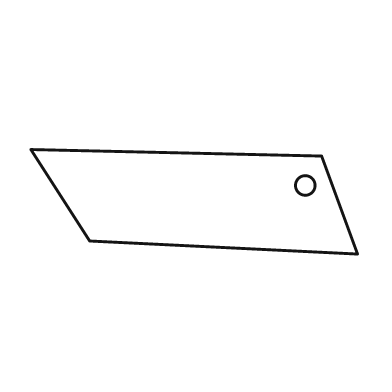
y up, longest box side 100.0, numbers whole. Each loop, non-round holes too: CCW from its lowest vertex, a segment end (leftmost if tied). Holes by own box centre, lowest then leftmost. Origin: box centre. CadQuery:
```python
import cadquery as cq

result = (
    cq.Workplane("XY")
    .moveTo(50.0, -16.0)
    .lineTo(39.0, 14.0)
    .lineTo(-50.0, 16.0)
    .lineTo(-32.0, -12.0)
    .close()
    .moveTo(34.0, 5.0)
    .circle(3.0)
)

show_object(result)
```